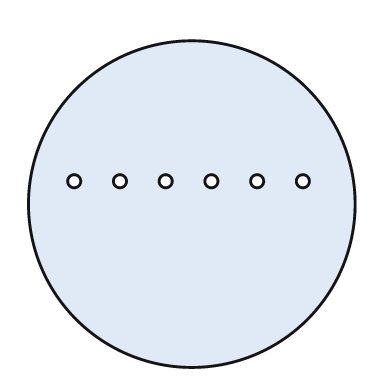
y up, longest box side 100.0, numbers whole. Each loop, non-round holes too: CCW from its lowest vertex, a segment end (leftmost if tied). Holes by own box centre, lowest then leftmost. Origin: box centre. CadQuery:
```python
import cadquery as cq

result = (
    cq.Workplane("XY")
    .moveTo(0.0, 0.0)
    .circle(50.0)
    .moveTo(-36.0, 7.0)
    .circle(2.0)
    .moveTo(-22.0, 7.0)
    .circle(2.0)
    .moveTo(-8.0, 7.0)
    .circle(2.0)
    .moveTo(6.0, 7.0)
    .circle(2.0)
    .moveTo(20.0, 7.0)
    .circle(2.0)
    .moveTo(34.0, 7.0)
    .circle(2.0)
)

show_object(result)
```